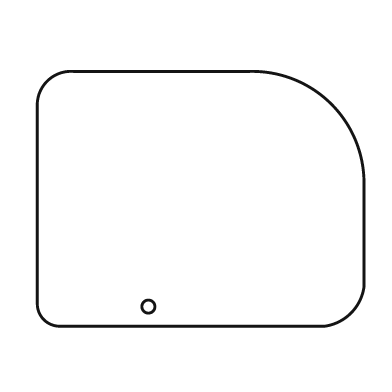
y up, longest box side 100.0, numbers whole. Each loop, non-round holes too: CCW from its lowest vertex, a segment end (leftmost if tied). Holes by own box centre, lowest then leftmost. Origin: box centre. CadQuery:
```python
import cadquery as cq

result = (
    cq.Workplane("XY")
    .moveTo(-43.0, -39.0)
    .lineTo(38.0, -39.0)
    .threePointArc((46.0, -35.0), (50.0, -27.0))
    .lineTo(50.0, 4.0)
    .threePointArc((40.0, 29.0), (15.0, 39.0))
    .lineTo(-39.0, 39.0)
    .threePointArc((-47.0, 36.0), (-50.0, 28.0))
    .lineTo(-50.0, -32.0)
    .threePointArc((-48.0, -37.0), (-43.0, -39.0))
    .close()
    .moveTo(-16.0, -33.0)
    .circle(2.0)
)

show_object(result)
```